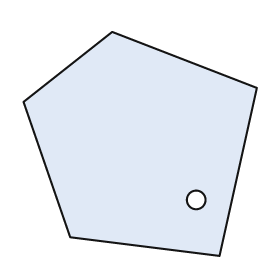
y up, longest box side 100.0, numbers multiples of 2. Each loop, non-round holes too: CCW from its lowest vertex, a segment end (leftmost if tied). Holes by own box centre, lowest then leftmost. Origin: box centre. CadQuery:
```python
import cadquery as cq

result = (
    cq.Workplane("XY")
    .moveTo(34.0, -48.0)
    .lineTo(50.0, 24.0)
    .lineTo(-12.0, 48.0)
    .lineTo(-50.0, 18.0)
    .lineTo(-30.0, -40.0)
    .close()
    .moveTo(24.0, -24.0)
    .circle(4.0)
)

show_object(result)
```